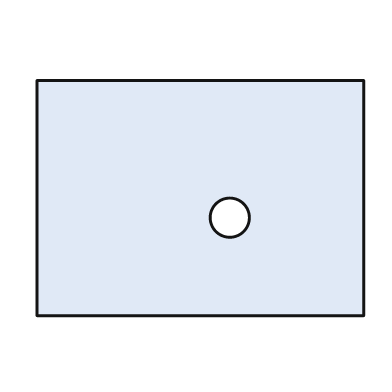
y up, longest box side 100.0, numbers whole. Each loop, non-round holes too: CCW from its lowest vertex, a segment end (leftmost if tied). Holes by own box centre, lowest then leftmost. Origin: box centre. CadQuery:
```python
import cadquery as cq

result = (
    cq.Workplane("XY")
    .moveTo(-50.0, -36.0)
    .lineTo(50.0, -36.0)
    .lineTo(50.0, 36.0)
    .lineTo(-50.0, 36.0)
    .close()
    .moveTo(9.0, -6.0)
    .circle(6.0)
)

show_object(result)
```